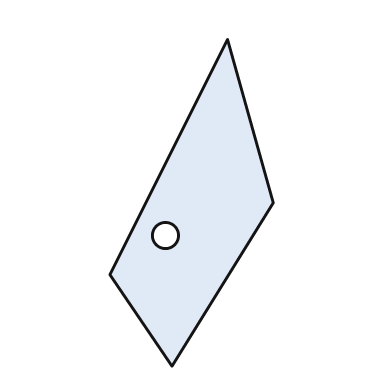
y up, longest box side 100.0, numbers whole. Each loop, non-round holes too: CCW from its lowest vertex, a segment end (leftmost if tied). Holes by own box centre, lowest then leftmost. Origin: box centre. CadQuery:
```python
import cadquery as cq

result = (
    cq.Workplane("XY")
    .moveTo(-6.0, -50.0)
    .lineTo(25.0, 0.0)
    .lineTo(11.0, 50.0)
    .lineTo(-25.0, -22.0)
    .close()
    .moveTo(-8.0, -10.0)
    .circle(4.0)
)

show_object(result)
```